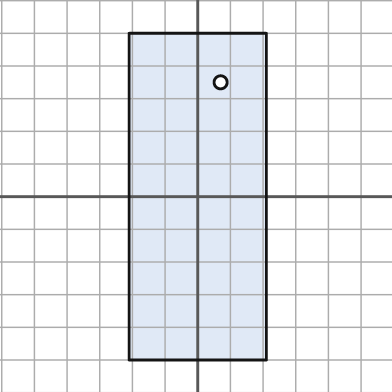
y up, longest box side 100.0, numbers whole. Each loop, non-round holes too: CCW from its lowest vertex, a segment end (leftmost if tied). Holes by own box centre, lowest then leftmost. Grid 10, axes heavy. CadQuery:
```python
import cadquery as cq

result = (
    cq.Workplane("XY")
    .moveTo(-21.0, -50.0)
    .lineTo(21.0, -50.0)
    .lineTo(21.0, 50.0)
    .lineTo(-21.0, 50.0)
    .close()
    .moveTo(7.0, 35.0)
    .circle(2.0)
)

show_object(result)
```